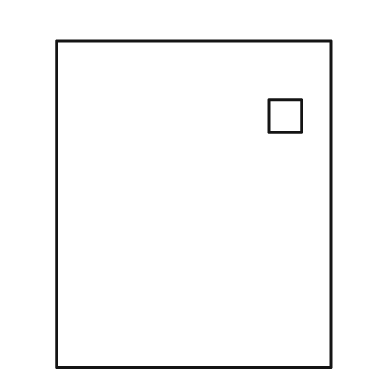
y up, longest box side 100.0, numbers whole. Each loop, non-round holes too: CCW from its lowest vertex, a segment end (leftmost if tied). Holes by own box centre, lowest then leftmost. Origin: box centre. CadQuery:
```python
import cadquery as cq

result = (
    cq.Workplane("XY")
    .moveTo(-42.0, -50.0)
    .lineTo(42.0, -50.0)
    .lineTo(42.0, 50.0)
    .lineTo(-42.0, 50.0)
    .close()
    .moveTo(23.0, 22.0)
    .lineTo(33.0, 22.0)
    .lineTo(33.0, 32.0)
    .lineTo(23.0, 32.0)
    .close()
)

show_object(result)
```